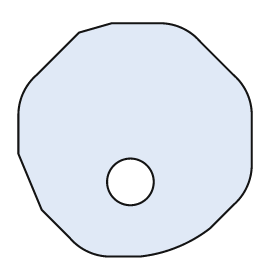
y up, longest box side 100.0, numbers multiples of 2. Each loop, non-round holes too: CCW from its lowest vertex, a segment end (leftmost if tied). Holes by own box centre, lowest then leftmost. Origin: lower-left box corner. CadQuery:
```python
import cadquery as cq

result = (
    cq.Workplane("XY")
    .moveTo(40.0, 0.0)
    .lineTo(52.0, 0.0)
    .threePointArc((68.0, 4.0), (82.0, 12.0))
    .lineTo(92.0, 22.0)
    .threePointArc((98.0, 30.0), (100.0, 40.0))
    .lineTo(100.0, 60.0)
    .threePointArc((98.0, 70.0), (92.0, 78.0))
    .lineTo(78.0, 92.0)
    .threePointArc((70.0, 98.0), (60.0, 100.0))
    .lineTo(40.0, 100.0)
    .lineTo(26.0, 96.0)
    .lineTo(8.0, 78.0)
    .threePointArc((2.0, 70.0), (0.0, 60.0))
    .lineTo(0.0, 44.0)
    .lineTo(10.0, 20.0)
    .lineTo(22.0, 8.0)
    .threePointArc((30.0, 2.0), (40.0, 0.0))
    .close()
    .moveTo(48.0, 32.0)
    .circle(10.0)
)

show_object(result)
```